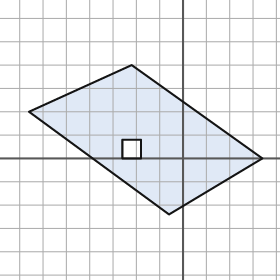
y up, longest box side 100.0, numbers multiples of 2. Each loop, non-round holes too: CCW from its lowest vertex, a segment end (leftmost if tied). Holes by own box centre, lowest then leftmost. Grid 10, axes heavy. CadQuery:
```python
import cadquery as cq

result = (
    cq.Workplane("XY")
    .moveTo(-6.0, -24.0)
    .lineTo(34.0, 0.0)
    .lineTo(-22.0, 40.0)
    .lineTo(-66.0, 20.0)
    .close()
    .moveTo(-26.0, 0.0)
    .lineTo(-18.0, 0.0)
    .lineTo(-18.0, 8.0)
    .lineTo(-26.0, 8.0)
    .close()
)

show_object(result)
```